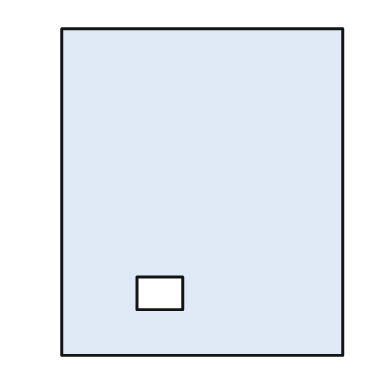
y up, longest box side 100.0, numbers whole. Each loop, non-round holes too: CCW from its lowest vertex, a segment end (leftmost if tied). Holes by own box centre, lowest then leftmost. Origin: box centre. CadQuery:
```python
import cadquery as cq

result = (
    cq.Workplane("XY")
    .moveTo(-43.0, -50.0)
    .lineTo(43.0, -50.0)
    .lineTo(43.0, 50.0)
    .lineTo(-43.0, 50.0)
    .close()
    .moveTo(-20.0, -36.0)
    .lineTo(-6.0, -36.0)
    .lineTo(-6.0, -26.0)
    .lineTo(-20.0, -26.0)
    .close()
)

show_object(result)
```